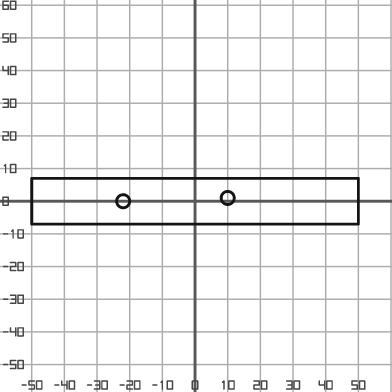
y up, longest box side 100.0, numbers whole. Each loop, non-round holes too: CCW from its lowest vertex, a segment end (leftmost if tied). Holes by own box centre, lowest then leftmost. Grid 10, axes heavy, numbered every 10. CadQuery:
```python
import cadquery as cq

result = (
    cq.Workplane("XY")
    .moveTo(-50.0, -7.0)
    .lineTo(50.0, -7.0)
    .lineTo(50.0, 7.0)
    .lineTo(-50.0, 7.0)
    .close()
    .moveTo(-22.0, 0.0)
    .circle(2.0)
    .moveTo(10.0, 1.0)
    .circle(2.0)
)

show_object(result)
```